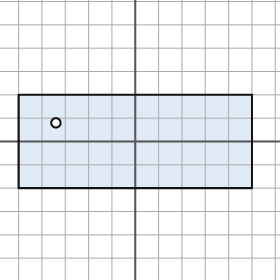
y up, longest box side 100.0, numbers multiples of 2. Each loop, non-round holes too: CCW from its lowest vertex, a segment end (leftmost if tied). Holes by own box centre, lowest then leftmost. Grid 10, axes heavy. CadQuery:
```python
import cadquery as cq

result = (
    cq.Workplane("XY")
    .moveTo(-50.0, -20.0)
    .lineTo(50.0, -20.0)
    .lineTo(50.0, 20.0)
    .lineTo(-50.0, 20.0)
    .close()
    .moveTo(-34.0, 8.0)
    .circle(2.0)
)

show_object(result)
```